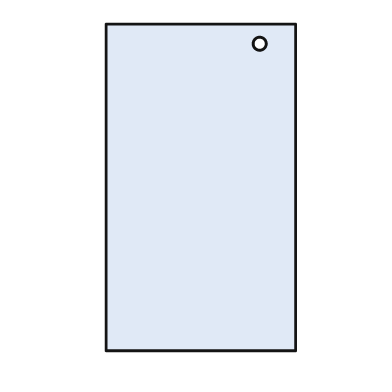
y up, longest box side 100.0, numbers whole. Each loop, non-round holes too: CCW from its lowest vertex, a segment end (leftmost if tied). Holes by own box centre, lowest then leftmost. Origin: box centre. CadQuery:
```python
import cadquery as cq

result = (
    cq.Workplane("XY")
    .moveTo(-29.0, -50.0)
    .lineTo(29.0, -50.0)
    .lineTo(29.0, 50.0)
    .lineTo(-29.0, 50.0)
    .close()
    .moveTo(18.0, 44.0)
    .circle(2.0)
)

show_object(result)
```